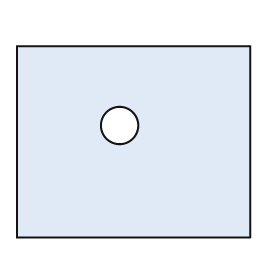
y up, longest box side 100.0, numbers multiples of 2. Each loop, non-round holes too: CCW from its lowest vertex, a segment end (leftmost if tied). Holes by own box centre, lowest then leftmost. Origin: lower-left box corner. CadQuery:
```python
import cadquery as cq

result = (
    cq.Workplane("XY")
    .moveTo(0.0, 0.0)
    .lineTo(100.0, 0.0)
    .lineTo(100.0, 82.0)
    .lineTo(0.0, 82.0)
    .close()
    .moveTo(44.0, 48.0)
    .circle(8.0)
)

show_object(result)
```